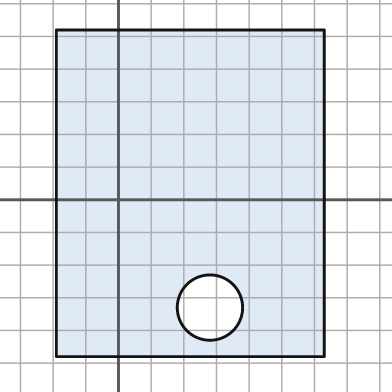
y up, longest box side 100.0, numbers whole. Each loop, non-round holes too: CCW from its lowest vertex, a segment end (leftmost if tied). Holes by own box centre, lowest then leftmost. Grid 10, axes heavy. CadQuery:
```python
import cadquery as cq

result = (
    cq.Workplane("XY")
    .moveTo(-19.0, -48.0)
    .lineTo(63.0, -48.0)
    .lineTo(63.0, 52.0)
    .lineTo(-19.0, 52.0)
    .close()
    .moveTo(28.0, -33.0)
    .circle(10.0)
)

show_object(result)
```